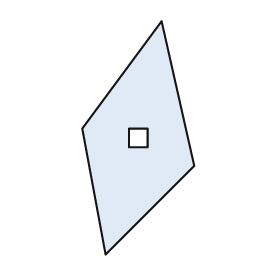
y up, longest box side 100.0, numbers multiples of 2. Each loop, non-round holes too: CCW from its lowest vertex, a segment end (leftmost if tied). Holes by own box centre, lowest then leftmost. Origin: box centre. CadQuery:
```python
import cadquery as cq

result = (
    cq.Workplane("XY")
    .moveTo(-14.0, -50.0)
    .lineTo(24.0, -12.0)
    .lineTo(10.0, 50.0)
    .lineTo(-24.0, 4.0)
    .close()
    .moveTo(-4.0, -4.0)
    .lineTo(4.0, -4.0)
    .lineTo(4.0, 4.0)
    .lineTo(-4.0, 4.0)
    .close()
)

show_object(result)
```